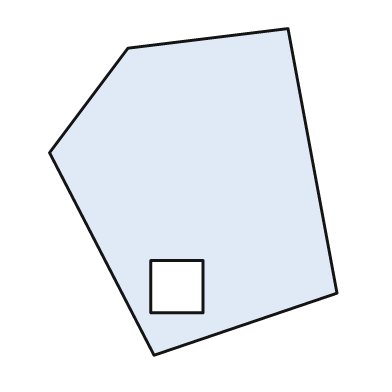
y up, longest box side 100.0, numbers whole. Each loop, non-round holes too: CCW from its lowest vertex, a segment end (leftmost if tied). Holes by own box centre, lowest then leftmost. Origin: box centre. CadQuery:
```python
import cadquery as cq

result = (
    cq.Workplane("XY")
    .moveTo(-12.0, -50.0)
    .lineTo(44.0, -31.0)
    .lineTo(29.0, 50.0)
    .lineTo(-20.0, 44.0)
    .lineTo(-44.0, 12.0)
    .close()
    .moveTo(-13.0, -37.0)
    .lineTo(3.0, -37.0)
    .lineTo(3.0, -21.0)
    .lineTo(-13.0, -21.0)
    .close()
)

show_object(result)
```